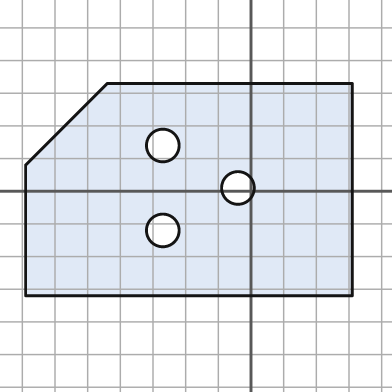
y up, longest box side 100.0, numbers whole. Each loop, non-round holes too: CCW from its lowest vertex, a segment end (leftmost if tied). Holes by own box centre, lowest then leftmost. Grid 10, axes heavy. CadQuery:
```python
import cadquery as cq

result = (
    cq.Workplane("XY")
    .moveTo(-69.0, -32.0)
    .lineTo(31.0, -32.0)
    .lineTo(31.0, 33.0)
    .lineTo(-44.0, 33.0)
    .lineTo(-69.0, 8.0)
    .close()
    .moveTo(-27.0, -12.0)
    .circle(5.0)
    .moveTo(-4.0, 1.0)
    .circle(5.0)
    .moveTo(-27.0, 14.0)
    .circle(5.0)
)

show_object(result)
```